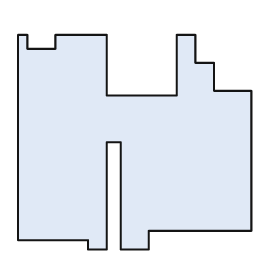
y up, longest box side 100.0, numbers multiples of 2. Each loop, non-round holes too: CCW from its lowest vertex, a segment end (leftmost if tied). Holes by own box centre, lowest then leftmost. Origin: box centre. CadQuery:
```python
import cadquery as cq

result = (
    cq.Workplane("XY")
    .moveTo(-20.0, -46.0)
    .lineTo(-12.0, -46.0)
    .lineTo(-12.0, 0.0)
    .lineTo(-6.0, 0.0)
    .lineTo(-6.0, -46.0)
    .lineTo(6.0, -46.0)
    .lineTo(6.0, -38.0)
    .lineTo(50.0, -38.0)
    .lineTo(50.0, 22.0)
    .lineTo(34.0, 22.0)
    .lineTo(34.0, 34.0)
    .lineTo(26.0, 34.0)
    .lineTo(26.0, 46.0)
    .lineTo(18.0, 46.0)
    .lineTo(18.0, 20.0)
    .lineTo(-12.0, 20.0)
    .lineTo(-12.0, 46.0)
    .lineTo(-34.0, 46.0)
    .lineTo(-34.0, 40.0)
    .lineTo(-46.0, 40.0)
    .lineTo(-46.0, 46.0)
    .lineTo(-50.0, 46.0)
    .lineTo(-50.0, -42.0)
    .lineTo(-20.0, -42.0)
    .close()
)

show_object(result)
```